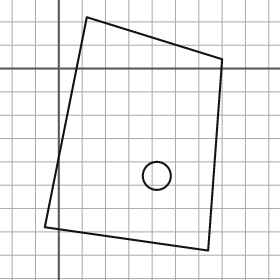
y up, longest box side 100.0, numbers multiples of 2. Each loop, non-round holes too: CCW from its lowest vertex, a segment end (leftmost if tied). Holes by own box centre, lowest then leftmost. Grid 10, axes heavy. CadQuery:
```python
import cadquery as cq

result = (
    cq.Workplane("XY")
    .moveTo(64.0, -78.0)
    .lineTo(70.0, 4.0)
    .lineTo(12.0, 22.0)
    .lineTo(-6.0, -68.0)
    .close()
    .moveTo(42.0, -46.0)
    .circle(6.0)
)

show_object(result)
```